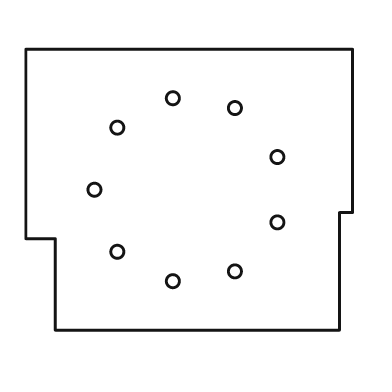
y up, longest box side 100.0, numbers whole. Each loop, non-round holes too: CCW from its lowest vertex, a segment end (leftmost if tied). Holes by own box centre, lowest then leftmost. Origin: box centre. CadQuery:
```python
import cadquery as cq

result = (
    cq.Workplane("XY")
    .moveTo(-41.0, -43.0)
    .lineTo(46.0, -43.0)
    .lineTo(46.0, -7.0)
    .lineTo(50.0, -7.0)
    .lineTo(50.0, 43.0)
    .lineTo(-50.0, 43.0)
    .lineTo(-50.0, -15.0)
    .lineTo(-41.0, -15.0)
    .close()
    .moveTo(-5.0, -28.0)
    .circle(2.0)
    .moveTo(14.0, -25.0)
    .circle(2.0)
    .moveTo(-22.0, -19.0)
    .circle(2.0)
    .moveTo(27.0, -10.0)
    .circle(2.0)
    .moveTo(-29.0, 0.0)
    .circle(2.0)
    .moveTo(27.0, 10.0)
    .circle(2.0)
    .moveTo(-22.0, 19.0)
    .circle(2.0)
    .moveTo(14.0, 25.0)
    .circle(2.0)
    .moveTo(-5.0, 28.0)
    .circle(2.0)
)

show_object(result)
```